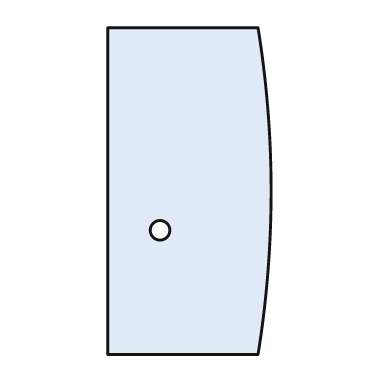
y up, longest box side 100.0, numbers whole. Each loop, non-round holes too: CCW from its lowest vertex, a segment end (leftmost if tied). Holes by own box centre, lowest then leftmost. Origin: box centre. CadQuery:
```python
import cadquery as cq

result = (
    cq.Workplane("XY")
    .moveTo(-25.0, -50.0)
    .lineTo(21.0, -50.0)
    .threePointArc((25.0, 0.0), (21.0, 50.0))
    .lineTo(-25.0, 50.0)
    .close()
    .moveTo(-9.0, -12.0)
    .circle(3.0)
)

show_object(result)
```